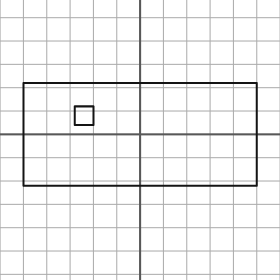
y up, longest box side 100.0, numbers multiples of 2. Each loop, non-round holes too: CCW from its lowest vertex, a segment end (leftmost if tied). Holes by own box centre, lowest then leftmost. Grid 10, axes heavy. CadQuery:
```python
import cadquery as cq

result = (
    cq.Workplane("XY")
    .moveTo(-50.0, -22.0)
    .lineTo(50.0, -22.0)
    .lineTo(50.0, 22.0)
    .lineTo(-50.0, 22.0)
    .close()
    .moveTo(-28.0, 4.0)
    .lineTo(-20.0, 4.0)
    .lineTo(-20.0, 12.0)
    .lineTo(-28.0, 12.0)
    .close()
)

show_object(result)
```